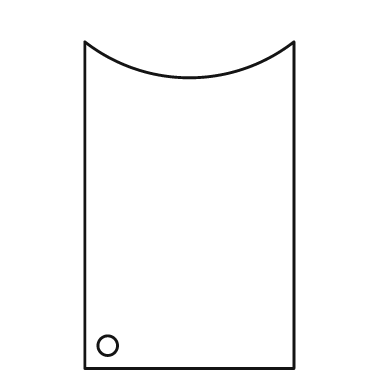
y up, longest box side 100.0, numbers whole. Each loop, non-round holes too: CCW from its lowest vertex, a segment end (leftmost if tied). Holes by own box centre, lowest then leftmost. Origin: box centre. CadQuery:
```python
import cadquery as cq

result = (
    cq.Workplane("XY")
    .moveTo(-32.0, -50.0)
    .lineTo(32.0, -50.0)
    .lineTo(32.0, 50.0)
    .threePointArc((0.0, 39.0), (-32.0, 50.0))
    .close()
    .moveTo(-25.0, -43.0)
    .circle(3.0)
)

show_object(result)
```